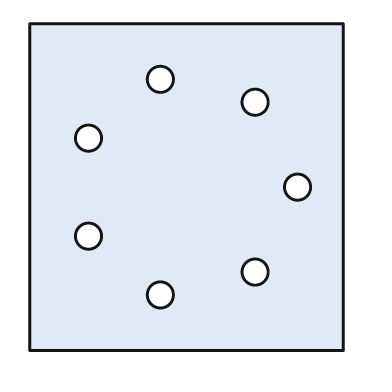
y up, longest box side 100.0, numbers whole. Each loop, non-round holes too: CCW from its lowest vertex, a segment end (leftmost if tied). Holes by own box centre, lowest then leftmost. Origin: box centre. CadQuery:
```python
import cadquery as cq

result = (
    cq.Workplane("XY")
    .moveTo(-48.0, -50.0)
    .lineTo(48.0, -50.0)
    .lineTo(48.0, 50.0)
    .lineTo(-48.0, 50.0)
    .close()
    .moveTo(-8.0, -33.0)
    .circle(4.0)
    .moveTo(21.0, -26.0)
    .circle(4.0)
    .moveTo(-30.0, -15.0)
    .circle(4.0)
    .moveTo(34.0, 0.0)
    .circle(4.0)
    .moveTo(-30.0, 15.0)
    .circle(4.0)
    .moveTo(21.0, 26.0)
    .circle(4.0)
    .moveTo(-8.0, 33.0)
    .circle(4.0)
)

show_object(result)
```